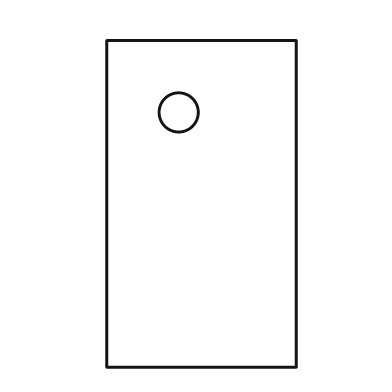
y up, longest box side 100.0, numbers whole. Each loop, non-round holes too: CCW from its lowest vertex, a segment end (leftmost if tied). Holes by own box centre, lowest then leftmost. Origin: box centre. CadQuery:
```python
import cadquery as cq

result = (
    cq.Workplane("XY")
    .moveTo(-29.0, -50.0)
    .lineTo(29.0, -50.0)
    .lineTo(29.0, 50.0)
    .lineTo(-29.0, 50.0)
    .close()
    .moveTo(-7.0, 28.0)
    .circle(6.0)
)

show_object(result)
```